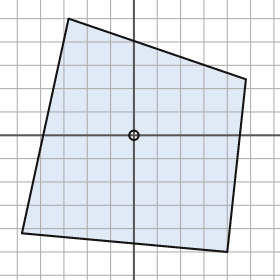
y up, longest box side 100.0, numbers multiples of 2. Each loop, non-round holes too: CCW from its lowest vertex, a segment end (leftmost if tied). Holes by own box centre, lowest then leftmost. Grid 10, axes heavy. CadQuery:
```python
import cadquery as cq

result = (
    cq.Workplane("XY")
    .moveTo(40.0, -50.0)
    .lineTo(48.0, 24.0)
    .lineTo(-28.0, 50.0)
    .lineTo(-48.0, -42.0)
    .close()
    .moveTo(0.0, 0.0)
    .circle(2.0)
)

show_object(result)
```